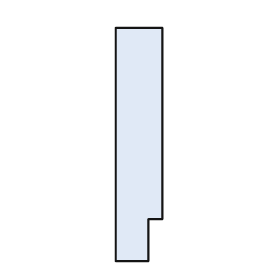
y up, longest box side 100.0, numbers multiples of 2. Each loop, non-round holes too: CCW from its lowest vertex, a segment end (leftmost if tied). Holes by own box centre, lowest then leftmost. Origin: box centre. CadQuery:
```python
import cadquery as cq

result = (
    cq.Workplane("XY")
    .moveTo(-10.0, -50.0)
    .lineTo(4.0, -50.0)
    .lineTo(4.0, -32.0)
    .lineTo(10.0, -32.0)
    .lineTo(10.0, 50.0)
    .lineTo(-10.0, 50.0)
    .close()
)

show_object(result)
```